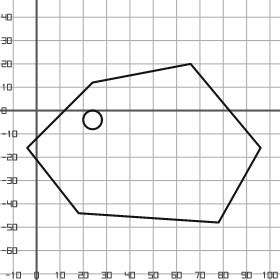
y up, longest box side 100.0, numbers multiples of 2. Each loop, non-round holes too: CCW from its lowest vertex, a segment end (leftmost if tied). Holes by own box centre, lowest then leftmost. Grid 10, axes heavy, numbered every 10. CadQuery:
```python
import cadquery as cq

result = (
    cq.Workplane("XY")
    .moveTo(78.0, -48.0)
    .lineTo(96.0, -16.0)
    .lineTo(66.0, 20.0)
    .lineTo(24.0, 12.0)
    .lineTo(-4.0, -16.0)
    .lineTo(18.0, -44.0)
    .close()
    .moveTo(24.0, -4.0)
    .circle(4.0)
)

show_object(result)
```